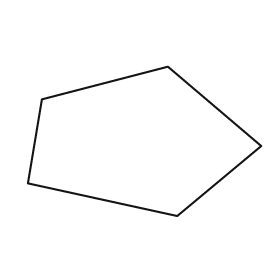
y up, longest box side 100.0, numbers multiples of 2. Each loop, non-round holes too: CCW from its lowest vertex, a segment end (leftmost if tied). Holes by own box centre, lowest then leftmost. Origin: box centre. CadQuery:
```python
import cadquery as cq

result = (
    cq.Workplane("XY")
    .moveTo(14.0, -32.0)
    .lineTo(50.0, -2.0)
    .lineTo(10.0, 32.0)
    .lineTo(-44.0, 18.0)
    .lineTo(-50.0, -18.0)
    .close()
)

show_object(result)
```